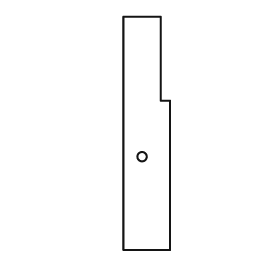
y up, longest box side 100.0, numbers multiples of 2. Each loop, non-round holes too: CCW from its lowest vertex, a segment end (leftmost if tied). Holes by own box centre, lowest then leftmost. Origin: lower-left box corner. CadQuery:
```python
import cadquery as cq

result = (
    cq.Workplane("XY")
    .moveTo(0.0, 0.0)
    .lineTo(20.0, 0.0)
    .lineTo(20.0, 64.0)
    .lineTo(16.0, 64.0)
    .lineTo(16.0, 100.0)
    .lineTo(0.0, 100.0)
    .close()
    .moveTo(8.0, 40.0)
    .circle(2.0)
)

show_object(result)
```